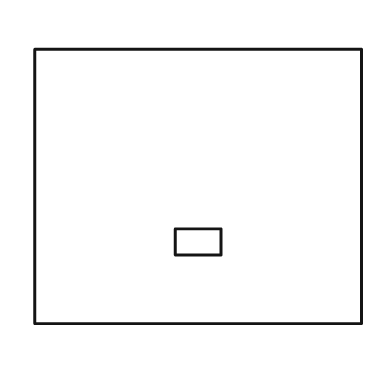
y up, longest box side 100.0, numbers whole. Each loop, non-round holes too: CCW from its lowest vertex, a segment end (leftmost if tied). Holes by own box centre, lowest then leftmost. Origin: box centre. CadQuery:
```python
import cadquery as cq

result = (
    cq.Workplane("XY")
    .moveTo(-50.0, -42.0)
    .lineTo(50.0, -42.0)
    .lineTo(50.0, 42.0)
    .lineTo(-50.0, 42.0)
    .close()
    .moveTo(-7.0, -21.0)
    .lineTo(7.0, -21.0)
    .lineTo(7.0, -13.0)
    .lineTo(-7.0, -13.0)
    .close()
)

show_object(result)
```